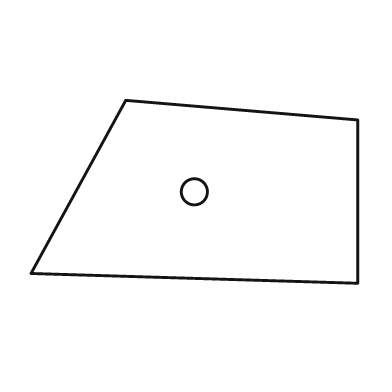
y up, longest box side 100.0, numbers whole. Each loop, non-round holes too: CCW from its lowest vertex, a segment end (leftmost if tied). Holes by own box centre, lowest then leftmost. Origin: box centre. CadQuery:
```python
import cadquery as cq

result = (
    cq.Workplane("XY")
    .moveTo(50.0, -28.0)
    .lineTo(50.0, 22.0)
    .lineTo(-21.0, 28.0)
    .lineTo(-50.0, -25.0)
    .close()
    .moveTo(0.0, 0.0)
    .circle(4.0)
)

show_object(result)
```